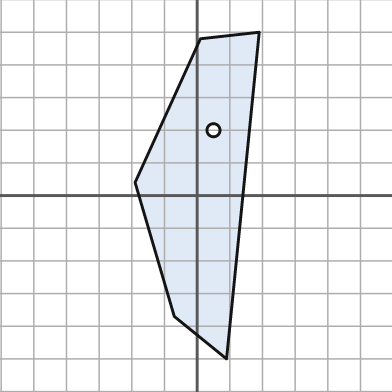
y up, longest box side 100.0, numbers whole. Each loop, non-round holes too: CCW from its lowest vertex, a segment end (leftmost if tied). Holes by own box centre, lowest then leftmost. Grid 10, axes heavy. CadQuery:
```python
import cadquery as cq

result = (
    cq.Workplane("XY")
    .moveTo(9.0, -50.0)
    .lineTo(19.0, 50.0)
    .lineTo(1.0, 48.0)
    .lineTo(-19.0, 4.0)
    .lineTo(-7.0, -37.0)
    .close()
    .moveTo(5.0, 20.0)
    .circle(2.0)
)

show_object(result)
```